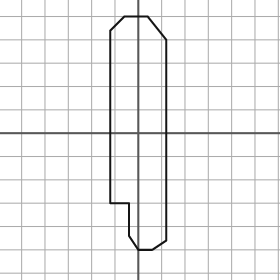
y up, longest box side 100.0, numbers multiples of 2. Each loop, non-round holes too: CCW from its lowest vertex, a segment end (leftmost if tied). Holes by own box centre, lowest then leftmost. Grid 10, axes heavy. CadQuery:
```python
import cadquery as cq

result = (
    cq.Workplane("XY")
    .moveTo(0.0, -50.0)
    .lineTo(6.0, -50.0)
    .lineTo(12.0, -46.0)
    .lineTo(12.0, 40.0)
    .lineTo(4.0, 50.0)
    .lineTo(-6.0, 50.0)
    .lineTo(-12.0, 44.0)
    .lineTo(-12.0, -30.0)
    .lineTo(-4.0, -30.0)
    .lineTo(-4.0, -44.0)
    .close()
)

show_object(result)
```